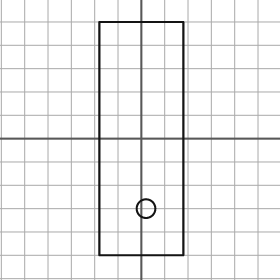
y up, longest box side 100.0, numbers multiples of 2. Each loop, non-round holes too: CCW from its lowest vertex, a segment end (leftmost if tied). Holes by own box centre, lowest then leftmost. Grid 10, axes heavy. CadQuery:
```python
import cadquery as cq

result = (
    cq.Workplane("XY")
    .moveTo(-18.0, -50.0)
    .lineTo(18.0, -50.0)
    .lineTo(18.0, 50.0)
    .lineTo(-18.0, 50.0)
    .close()
    .moveTo(2.0, -30.0)
    .circle(4.0)
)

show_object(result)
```